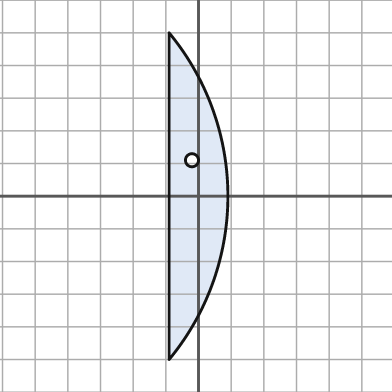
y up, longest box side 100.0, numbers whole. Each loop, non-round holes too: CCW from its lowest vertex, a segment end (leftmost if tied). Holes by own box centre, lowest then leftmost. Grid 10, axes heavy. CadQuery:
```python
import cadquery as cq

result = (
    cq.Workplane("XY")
    .moveTo(-9.0, -50.0)
    .threePointArc((9.0, 0.0), (-9.0, 50.0))
    .close()
    .moveTo(-2.0, 11.0)
    .circle(2.0)
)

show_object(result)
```